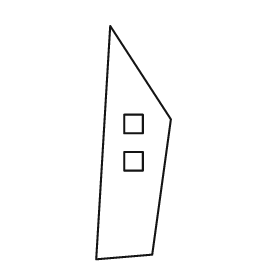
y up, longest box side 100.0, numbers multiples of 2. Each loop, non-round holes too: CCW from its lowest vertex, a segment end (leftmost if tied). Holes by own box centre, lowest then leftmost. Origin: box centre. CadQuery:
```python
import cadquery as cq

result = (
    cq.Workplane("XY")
    .moveTo(-16.0, -50.0)
    .lineTo(8.0, -48.0)
    .lineTo(16.0, 10.0)
    .lineTo(-10.0, 50.0)
    .close()
    .moveTo(-4.0, -12.0)
    .lineTo(4.0, -12.0)
    .lineTo(4.0, -4.0)
    .lineTo(-4.0, -4.0)
    .close()
    .moveTo(-4.0, 4.0)
    .lineTo(4.0, 4.0)
    .lineTo(4.0, 12.0)
    .lineTo(-4.0, 12.0)
    .close()
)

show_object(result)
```